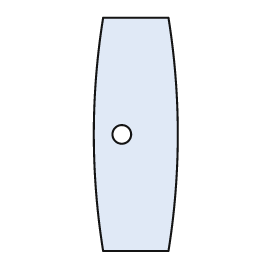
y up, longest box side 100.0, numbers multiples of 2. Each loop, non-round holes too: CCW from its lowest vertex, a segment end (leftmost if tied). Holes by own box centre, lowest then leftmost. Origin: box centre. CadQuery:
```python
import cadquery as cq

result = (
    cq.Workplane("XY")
    .moveTo(-14.0, -50.0)
    .lineTo(14.0, -50.0)
    .threePointArc((18.0, 0.0), (14.0, 50.0))
    .lineTo(-14.0, 50.0)
    .threePointArc((-18.0, 0.0), (-14.0, -50.0))
    .close()
    .moveTo(-6.0, 0.0)
    .circle(4.0)
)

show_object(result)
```